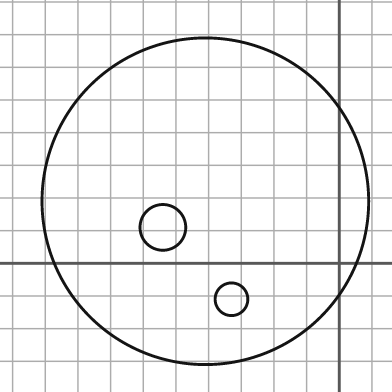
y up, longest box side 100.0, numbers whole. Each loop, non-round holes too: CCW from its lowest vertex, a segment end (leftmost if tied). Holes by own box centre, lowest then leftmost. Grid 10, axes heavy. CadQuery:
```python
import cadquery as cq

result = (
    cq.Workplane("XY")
    .moveTo(-41.0, 19.0)
    .circle(50.0)
    .moveTo(-33.0, -11.0)
    .circle(5.0)
    .moveTo(-54.0, 11.0)
    .circle(7.0)
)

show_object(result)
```